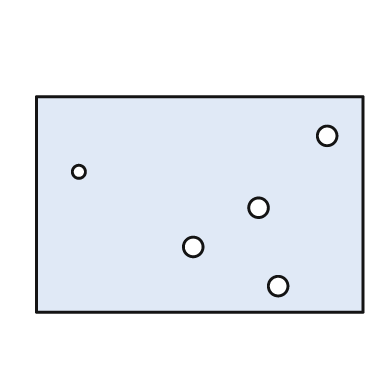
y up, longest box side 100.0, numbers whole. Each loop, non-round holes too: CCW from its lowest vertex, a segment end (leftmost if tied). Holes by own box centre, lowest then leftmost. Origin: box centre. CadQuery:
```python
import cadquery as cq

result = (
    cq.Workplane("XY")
    .moveTo(-50.0, -33.0)
    .lineTo(50.0, -33.0)
    .lineTo(50.0, 33.0)
    .lineTo(-50.0, 33.0)
    .close()
    .moveTo(24.0, -25.0)
    .circle(3.0)
    .moveTo(-2.0, -13.0)
    .circle(3.0)
    .moveTo(18.0, -1.0)
    .circle(3.0)
    .moveTo(-37.0, 10.0)
    .circle(2.0)
    .moveTo(39.0, 21.0)
    .circle(3.0)
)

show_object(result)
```